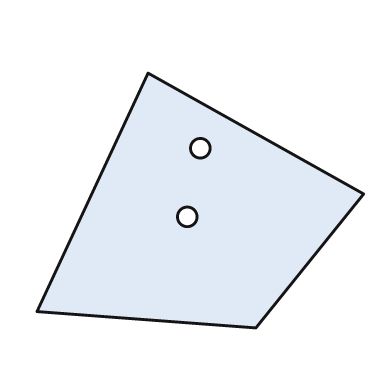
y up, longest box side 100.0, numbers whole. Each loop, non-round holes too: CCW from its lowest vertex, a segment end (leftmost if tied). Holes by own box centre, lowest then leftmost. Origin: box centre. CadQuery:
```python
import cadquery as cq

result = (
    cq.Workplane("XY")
    .moveTo(17.0, -39.0)
    .lineTo(50.0, 2.0)
    .lineTo(-16.0, 39.0)
    .lineTo(-50.0, -34.0)
    .close()
    .moveTo(-4.0, -5.0)
    .circle(3.0)
    .moveTo(0.0, 16.0)
    .circle(3.0)
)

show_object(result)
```